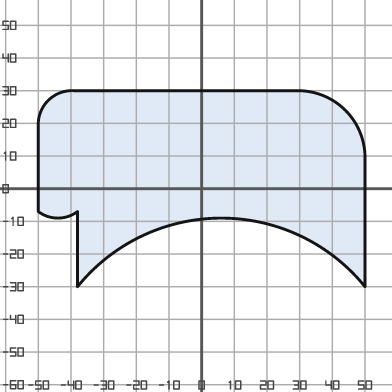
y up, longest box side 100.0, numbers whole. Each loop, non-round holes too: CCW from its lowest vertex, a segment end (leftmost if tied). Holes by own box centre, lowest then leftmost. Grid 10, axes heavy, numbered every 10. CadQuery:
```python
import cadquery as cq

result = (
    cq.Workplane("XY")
    .moveTo(-38.0, -30.0)
    .threePointArc((6.0, -9.0), (50.0, -30.0))
    .lineTo(50.0, 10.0)
    .threePointArc((44.0, 24.0), (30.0, 30.0))
    .lineTo(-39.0, 30.0)
    .threePointArc((-47.0, 27.0), (-50.0, 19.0))
    .lineTo(-50.0, -7.0)
    .threePointArc((-44.0, -9.0), (-38.0, -7.0))
    .close()
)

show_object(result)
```